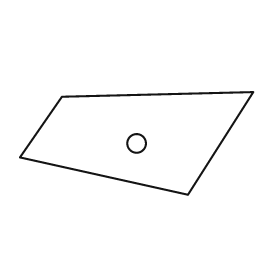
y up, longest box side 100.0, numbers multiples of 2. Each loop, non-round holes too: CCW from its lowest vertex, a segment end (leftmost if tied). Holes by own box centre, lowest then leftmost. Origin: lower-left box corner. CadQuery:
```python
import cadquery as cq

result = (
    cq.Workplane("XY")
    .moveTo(72.0, 0.0)
    .lineTo(100.0, 44.0)
    .lineTo(18.0, 42.0)
    .lineTo(0.0, 16.0)
    .close()
    .moveTo(50.0, 22.0)
    .circle(4.0)
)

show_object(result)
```